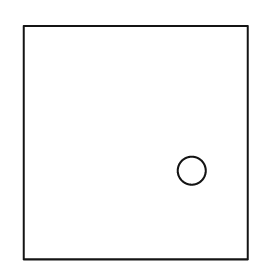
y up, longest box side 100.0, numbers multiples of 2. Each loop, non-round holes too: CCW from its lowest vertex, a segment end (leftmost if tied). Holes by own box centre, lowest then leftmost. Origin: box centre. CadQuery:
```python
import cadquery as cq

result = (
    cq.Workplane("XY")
    .moveTo(-48.0, -50.0)
    .lineTo(48.0, -50.0)
    .lineTo(48.0, 50.0)
    .lineTo(-48.0, 50.0)
    .close()
    .moveTo(24.0, -12.0)
    .circle(6.0)
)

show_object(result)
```